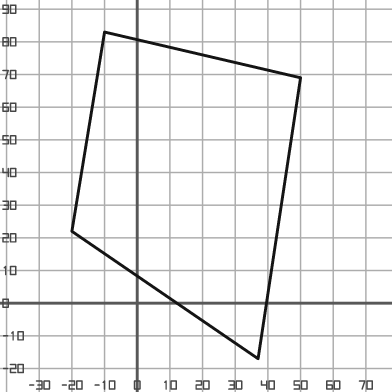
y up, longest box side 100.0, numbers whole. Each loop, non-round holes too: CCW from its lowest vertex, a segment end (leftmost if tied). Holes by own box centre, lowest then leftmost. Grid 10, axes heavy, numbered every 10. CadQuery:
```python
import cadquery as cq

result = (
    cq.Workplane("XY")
    .moveTo(37.0, -17.0)
    .lineTo(50.0, 69.0)
    .lineTo(-10.0, 83.0)
    .lineTo(-20.0, 22.0)
    .close()
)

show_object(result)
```